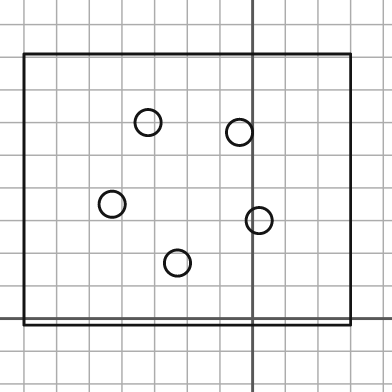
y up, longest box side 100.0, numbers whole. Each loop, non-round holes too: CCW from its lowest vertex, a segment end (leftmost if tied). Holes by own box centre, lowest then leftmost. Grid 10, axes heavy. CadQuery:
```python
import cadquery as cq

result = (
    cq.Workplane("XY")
    .moveTo(-70.0, -2.0)
    .lineTo(30.0, -2.0)
    .lineTo(30.0, 81.0)
    .lineTo(-70.0, 81.0)
    .close()
    .moveTo(-23.0, 17.0)
    .circle(4.0)
    .moveTo(2.0, 30.0)
    .circle(4.0)
    .moveTo(-43.0, 35.0)
    .circle(4.0)
    .moveTo(-4.0, 57.0)
    .circle(4.0)
    .moveTo(-32.0, 60.0)
    .circle(4.0)
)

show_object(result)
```